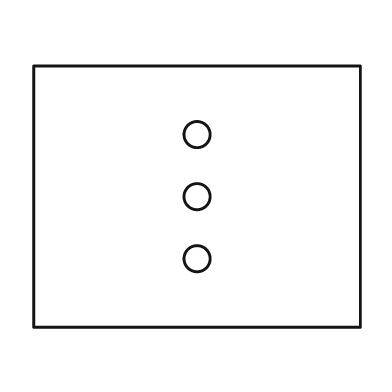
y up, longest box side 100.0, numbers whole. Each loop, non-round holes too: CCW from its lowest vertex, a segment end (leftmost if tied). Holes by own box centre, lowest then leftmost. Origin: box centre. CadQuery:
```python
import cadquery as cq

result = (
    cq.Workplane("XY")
    .moveTo(-50.0, -40.0)
    .lineTo(50.0, -40.0)
    .lineTo(50.0, 40.0)
    .lineTo(-50.0, 40.0)
    .close()
    .moveTo(0.0, -19.0)
    .circle(4.0)
    .moveTo(0.0, 0.0)
    .circle(4.0)
    .moveTo(0.0, 19.0)
    .circle(4.0)
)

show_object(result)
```